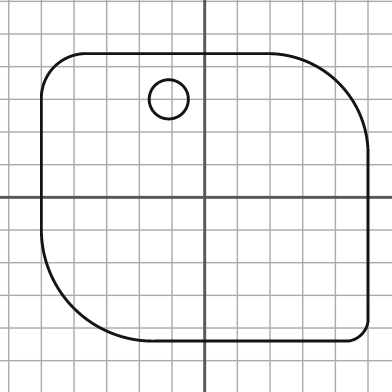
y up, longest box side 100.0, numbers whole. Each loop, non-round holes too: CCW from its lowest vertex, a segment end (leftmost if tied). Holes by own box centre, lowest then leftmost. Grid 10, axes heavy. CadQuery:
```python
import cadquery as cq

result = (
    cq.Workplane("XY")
    .moveTo(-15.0, -44.0)
    .lineTo(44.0, -44.0)
    .threePointArc((48.0, -42.0), (50.0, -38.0))
    .lineTo(50.0, 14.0)
    .threePointArc((41.0, 35.0), (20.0, 44.0))
    .lineTo(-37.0, 44.0)
    .threePointArc((-46.0, 40.0), (-50.0, 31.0))
    .lineTo(-50.0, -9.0)
    .threePointArc((-40.0, -34.0), (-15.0, -44.0))
    .close()
    .moveTo(-11.0, 30.0)
    .circle(6.0)
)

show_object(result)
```